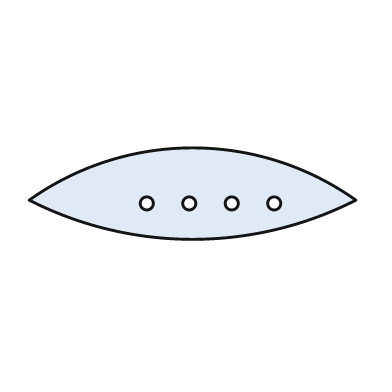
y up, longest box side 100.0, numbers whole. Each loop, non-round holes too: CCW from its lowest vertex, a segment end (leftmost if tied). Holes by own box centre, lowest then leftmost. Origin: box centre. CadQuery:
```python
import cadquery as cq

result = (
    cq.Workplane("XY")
    .moveTo(-50.0, -2.0)
    .threePointArc((0.0, -14.0), (50.0, -2.0))
    .threePointArc((0.0, 14.0), (-50.0, -2.0))
    .close()
    .moveTo(-14.0, -3.0)
    .circle(2.0)
    .moveTo(-1.0, -3.0)
    .circle(2.0)
    .moveTo(12.0, -3.0)
    .circle(2.0)
    .moveTo(25.0, -3.0)
    .circle(2.0)
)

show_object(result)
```